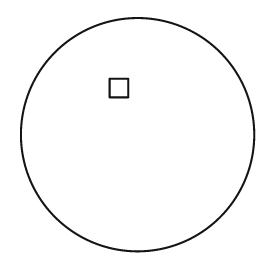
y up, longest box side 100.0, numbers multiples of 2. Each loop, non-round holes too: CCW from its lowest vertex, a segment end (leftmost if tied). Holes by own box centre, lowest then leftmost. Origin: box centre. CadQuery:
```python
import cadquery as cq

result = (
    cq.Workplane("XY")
    .moveTo(0.0, 0.0)
    .circle(50.0)
    .moveTo(-12.0, 16.0)
    .lineTo(-4.0, 16.0)
    .lineTo(-4.0, 24.0)
    .lineTo(-12.0, 24.0)
    .close()
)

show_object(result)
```